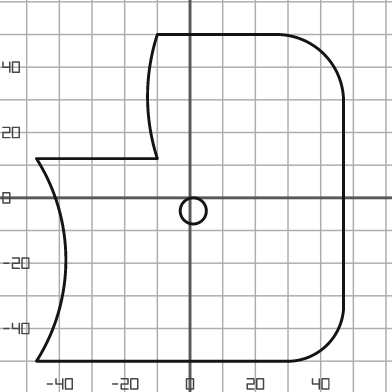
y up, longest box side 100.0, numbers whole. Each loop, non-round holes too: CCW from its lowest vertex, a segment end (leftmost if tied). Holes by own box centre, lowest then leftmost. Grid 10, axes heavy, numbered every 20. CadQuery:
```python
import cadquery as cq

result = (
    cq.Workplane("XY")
    .moveTo(-47.0, -50.0)
    .lineTo(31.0, -50.0)
    .threePointArc((42.0, -45.0), (47.0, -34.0))
    .lineTo(47.0, 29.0)
    .threePointArc((41.0, 44.0), (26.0, 50.0))
    .lineTo(-10.0, 50.0)
    .threePointArc((-13.0, 31.0), (-10.0, 12.0))
    .lineTo(-47.0, 12.0)
    .threePointArc((-38.0, -19.0), (-47.0, -50.0))
    .close()
    .moveTo(1.0, -4.0)
    .circle(4.0)
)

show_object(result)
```